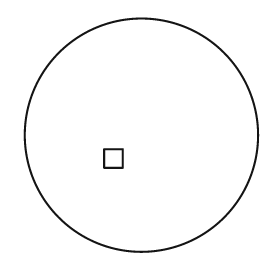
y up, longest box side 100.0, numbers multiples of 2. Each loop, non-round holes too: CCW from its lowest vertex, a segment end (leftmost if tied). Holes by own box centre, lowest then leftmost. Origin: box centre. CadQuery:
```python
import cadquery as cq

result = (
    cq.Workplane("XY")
    .moveTo(0.0, 0.0)
    .circle(50.0)
    .moveTo(-16.0, -14.0)
    .lineTo(-8.0, -14.0)
    .lineTo(-8.0, -6.0)
    .lineTo(-16.0, -6.0)
    .close()
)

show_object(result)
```